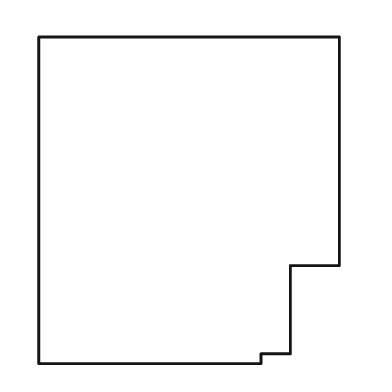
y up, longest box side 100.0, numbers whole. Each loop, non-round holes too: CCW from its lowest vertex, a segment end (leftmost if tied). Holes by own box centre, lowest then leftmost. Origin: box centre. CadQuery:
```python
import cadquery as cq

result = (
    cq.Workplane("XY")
    .moveTo(-46.0, -50.0)
    .lineTo(22.0, -50.0)
    .lineTo(22.0, -47.0)
    .lineTo(31.0, -47.0)
    .lineTo(31.0, -20.0)
    .lineTo(46.0, -20.0)
    .lineTo(46.0, 50.0)
    .lineTo(-46.0, 50.0)
    .close()
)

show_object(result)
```